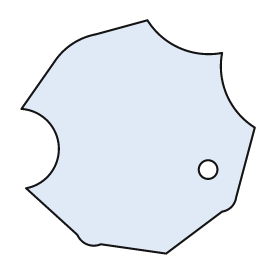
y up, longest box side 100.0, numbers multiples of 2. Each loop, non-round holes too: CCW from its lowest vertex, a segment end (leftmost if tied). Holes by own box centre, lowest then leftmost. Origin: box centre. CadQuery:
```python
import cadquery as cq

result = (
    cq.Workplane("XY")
    .moveTo(12.0, -50.0)
    .lineTo(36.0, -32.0)
    .threePointArc((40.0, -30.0), (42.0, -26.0))
    .lineTo(50.0, 4.0)
    .threePointArc((38.0, 18.0), (36.0, 36.0))
    .threePointArc((18.0, 38.0), (4.0, 50.0))
    .lineTo(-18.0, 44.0)
    .threePointArc((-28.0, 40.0), (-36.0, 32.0))
    .lineTo(-50.0, 12.0)
    .threePointArc((-34.0, -4.0), (-48.0, -22.0))
    .lineTo(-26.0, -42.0)
    .threePointArc((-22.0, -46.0), (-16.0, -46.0))
    .close()
    .moveTo(30.0, -14.0)
    .circle(4.0)
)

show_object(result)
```